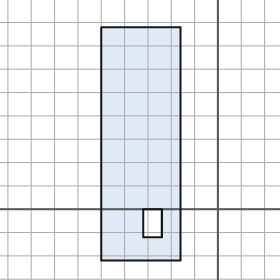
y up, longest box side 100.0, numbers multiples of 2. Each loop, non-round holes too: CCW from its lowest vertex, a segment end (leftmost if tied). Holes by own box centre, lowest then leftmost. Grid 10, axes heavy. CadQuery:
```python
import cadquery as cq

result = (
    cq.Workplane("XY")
    .moveTo(-50.0, -22.0)
    .lineTo(-16.0, -22.0)
    .lineTo(-16.0, 78.0)
    .lineTo(-50.0, 78.0)
    .close()
    .moveTo(-32.0, -12.0)
    .lineTo(-24.0, -12.0)
    .lineTo(-24.0, 0.0)
    .lineTo(-32.0, 0.0)
    .close()
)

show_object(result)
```